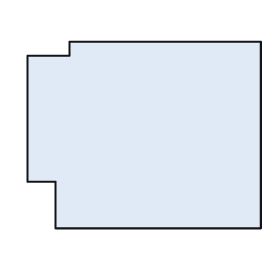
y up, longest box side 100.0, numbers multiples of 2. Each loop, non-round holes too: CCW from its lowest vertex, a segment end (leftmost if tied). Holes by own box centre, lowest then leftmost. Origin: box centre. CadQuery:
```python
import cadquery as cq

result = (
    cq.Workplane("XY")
    .moveTo(-38.0, -40.0)
    .lineTo(50.0, -40.0)
    .lineTo(50.0, 40.0)
    .lineTo(-32.0, 40.0)
    .lineTo(-32.0, 34.0)
    .lineTo(-50.0, 34.0)
    .lineTo(-50.0, -20.0)
    .lineTo(-38.0, -20.0)
    .close()
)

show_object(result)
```